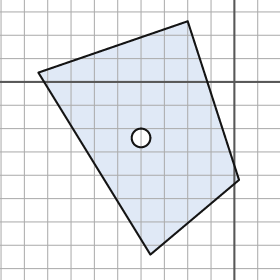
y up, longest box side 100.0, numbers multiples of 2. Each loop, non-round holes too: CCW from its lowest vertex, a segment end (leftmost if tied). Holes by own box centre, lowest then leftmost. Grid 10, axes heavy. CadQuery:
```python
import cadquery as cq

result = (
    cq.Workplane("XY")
    .moveTo(-36.0, -74.0)
    .lineTo(2.0, -42.0)
    .lineTo(-20.0, 26.0)
    .lineTo(-84.0, 4.0)
    .close()
    .moveTo(-40.0, -24.0)
    .circle(4.0)
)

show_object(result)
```